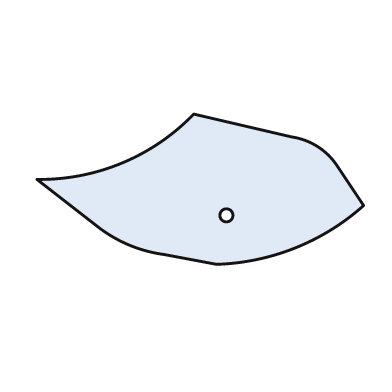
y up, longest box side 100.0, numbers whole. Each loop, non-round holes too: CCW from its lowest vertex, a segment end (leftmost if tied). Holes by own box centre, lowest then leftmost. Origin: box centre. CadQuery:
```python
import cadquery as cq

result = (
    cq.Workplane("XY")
    .moveTo(5.0, -23.0)
    .threePointArc((29.0, -18.0), (50.0, -5.0))
    .lineTo(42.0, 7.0)
    .threePointArc((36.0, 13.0), (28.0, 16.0))
    .lineTo(-2.0, 23.0)
    .threePointArc((-24.0, 8.0), (-50.0, 3.0))
    .lineTo(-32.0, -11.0)
    .threePointArc((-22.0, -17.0), (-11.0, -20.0))
    .close()
    .moveTo(8.0, -8.0)
    .circle(2.0)
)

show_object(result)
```